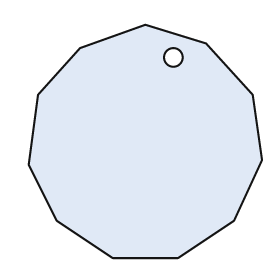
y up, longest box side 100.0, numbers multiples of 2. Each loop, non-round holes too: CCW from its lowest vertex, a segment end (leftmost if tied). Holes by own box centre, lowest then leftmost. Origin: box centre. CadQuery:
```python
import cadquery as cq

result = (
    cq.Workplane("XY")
    .moveTo(-14.0, -50.0)
    .lineTo(14.0, -50.0)
    .lineTo(38.0, -34.0)
    .lineTo(50.0, -8.0)
    .lineTo(46.0, 20.0)
    .lineTo(26.0, 42.0)
    .lineTo(0.0, 50.0)
    .lineTo(-28.0, 40.0)
    .lineTo(-46.0, 20.0)
    .lineTo(-50.0, -10.0)
    .lineTo(-38.0, -34.0)
    .close()
    .moveTo(12.0, 36.0)
    .circle(4.0)
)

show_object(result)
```